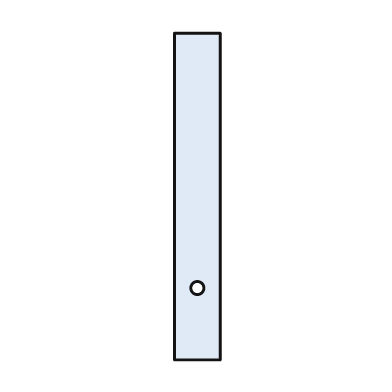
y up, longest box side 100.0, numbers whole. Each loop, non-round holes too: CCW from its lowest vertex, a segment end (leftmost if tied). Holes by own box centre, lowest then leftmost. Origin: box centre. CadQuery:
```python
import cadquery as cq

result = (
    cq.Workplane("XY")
    .moveTo(-7.0, -50.0)
    .lineTo(7.0, -50.0)
    .lineTo(7.0, 50.0)
    .lineTo(-7.0, 50.0)
    .close()
    .moveTo(0.0, -28.0)
    .circle(2.0)
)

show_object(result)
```